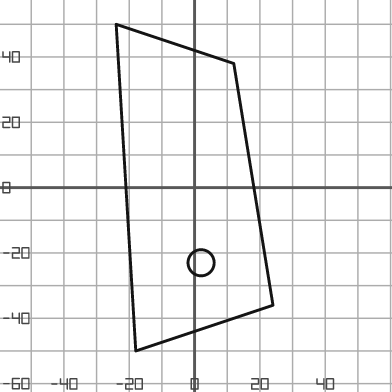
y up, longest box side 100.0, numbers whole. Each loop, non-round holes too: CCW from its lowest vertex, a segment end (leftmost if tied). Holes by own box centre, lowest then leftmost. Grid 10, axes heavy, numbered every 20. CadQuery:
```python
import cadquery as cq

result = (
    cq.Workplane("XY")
    .moveTo(-18.0, -50.0)
    .lineTo(24.0, -36.0)
    .lineTo(12.0, 38.0)
    .lineTo(-24.0, 50.0)
    .close()
    .moveTo(2.0, -23.0)
    .circle(4.0)
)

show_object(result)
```